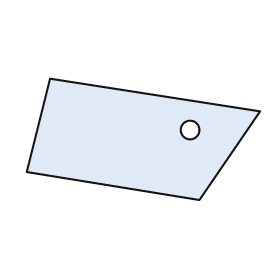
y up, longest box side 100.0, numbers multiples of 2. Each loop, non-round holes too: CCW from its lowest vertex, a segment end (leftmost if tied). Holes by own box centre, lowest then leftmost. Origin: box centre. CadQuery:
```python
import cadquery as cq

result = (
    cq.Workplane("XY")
    .moveTo(24.0, -26.0)
    .lineTo(50.0, 12.0)
    .lineTo(-40.0, 26.0)
    .lineTo(-50.0, -14.0)
    .close()
    .moveTo(20.0, 4.0)
    .circle(4.0)
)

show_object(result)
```